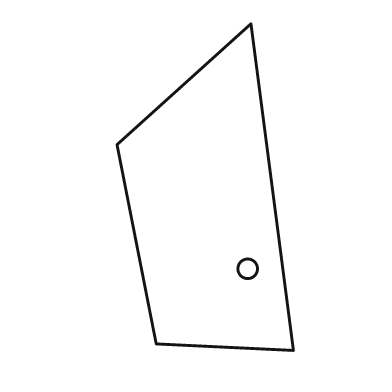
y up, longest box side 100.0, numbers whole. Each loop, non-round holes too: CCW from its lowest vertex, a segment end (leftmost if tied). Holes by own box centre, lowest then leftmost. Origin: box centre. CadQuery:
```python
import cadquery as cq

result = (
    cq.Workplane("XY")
    .moveTo(27.0, -50.0)
    .lineTo(14.0, 50.0)
    .lineTo(-27.0, 13.0)
    .lineTo(-15.0, -48.0)
    .close()
    .moveTo(13.0, -25.0)
    .circle(3.0)
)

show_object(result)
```